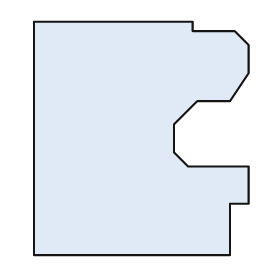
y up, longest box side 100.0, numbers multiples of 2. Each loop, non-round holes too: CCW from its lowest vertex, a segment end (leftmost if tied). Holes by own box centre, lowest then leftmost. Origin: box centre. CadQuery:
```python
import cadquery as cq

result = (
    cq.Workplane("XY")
    .moveTo(-46.0, -50.0)
    .lineTo(38.0, -50.0)
    .lineTo(38.0, -28.0)
    .lineTo(46.0, -28.0)
    .lineTo(46.0, -12.0)
    .lineTo(20.0, -12.0)
    .lineTo(14.0, -6.0)
    .lineTo(14.0, 6.0)
    .lineTo(24.0, 16.0)
    .lineTo(38.0, 16.0)
    .lineTo(46.0, 28.0)
    .lineTo(46.0, 40.0)
    .lineTo(40.0, 46.0)
    .lineTo(22.0, 46.0)
    .lineTo(22.0, 50.0)
    .lineTo(-46.0, 50.0)
    .close()
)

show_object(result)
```